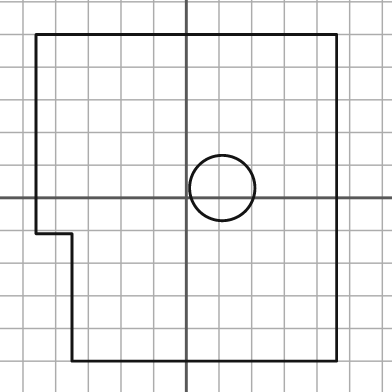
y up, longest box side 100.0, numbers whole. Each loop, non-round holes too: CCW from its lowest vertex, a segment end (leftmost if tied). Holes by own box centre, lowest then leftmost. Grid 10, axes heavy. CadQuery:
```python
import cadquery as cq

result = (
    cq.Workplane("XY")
    .moveTo(-35.0, -50.0)
    .lineTo(46.0, -50.0)
    .lineTo(46.0, 50.0)
    .lineTo(-46.0, 50.0)
    .lineTo(-46.0, -11.0)
    .lineTo(-35.0, -11.0)
    .close()
    .moveTo(11.0, 3.0)
    .circle(10.0)
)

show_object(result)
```